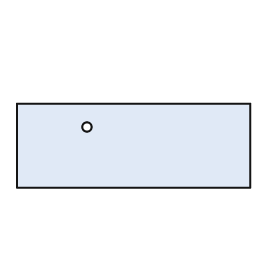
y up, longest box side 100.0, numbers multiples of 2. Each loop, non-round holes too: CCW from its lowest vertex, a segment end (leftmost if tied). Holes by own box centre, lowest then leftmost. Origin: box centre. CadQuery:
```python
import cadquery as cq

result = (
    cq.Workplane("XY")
    .moveTo(-50.0, -18.0)
    .lineTo(50.0, -18.0)
    .lineTo(50.0, 18.0)
    .lineTo(-50.0, 18.0)
    .close()
    .moveTo(-20.0, 8.0)
    .circle(2.0)
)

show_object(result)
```